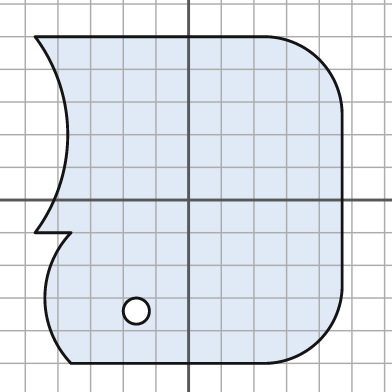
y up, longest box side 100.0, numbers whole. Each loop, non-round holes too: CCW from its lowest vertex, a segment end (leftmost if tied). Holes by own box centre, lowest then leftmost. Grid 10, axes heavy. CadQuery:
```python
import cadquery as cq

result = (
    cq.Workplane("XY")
    .moveTo(-36.0, -50.0)
    .lineTo(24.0, -50.0)
    .threePointArc((40.0, -43.0), (47.0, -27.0))
    .lineTo(47.0, 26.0)
    .threePointArc((40.0, 43.0), (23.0, 50.0))
    .lineTo(-47.0, 50.0)
    .threePointArc((-37.0, 20.0), (-47.0, -10.0))
    .lineTo(-36.0, -10.0)
    .threePointArc((-44.0, -30.0), (-36.0, -50.0))
    .close()
    .moveTo(-16.0, -34.0)
    .circle(4.0)
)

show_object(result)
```